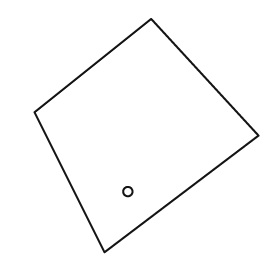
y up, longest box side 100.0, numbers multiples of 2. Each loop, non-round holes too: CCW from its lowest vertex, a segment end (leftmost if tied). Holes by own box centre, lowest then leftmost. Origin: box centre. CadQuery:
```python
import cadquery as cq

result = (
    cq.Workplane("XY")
    .moveTo(-18.0, -50.0)
    .lineTo(48.0, 0.0)
    .lineTo(2.0, 50.0)
    .lineTo(-48.0, 10.0)
    .close()
    .moveTo(-8.0, -24.0)
    .circle(2.0)
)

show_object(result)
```